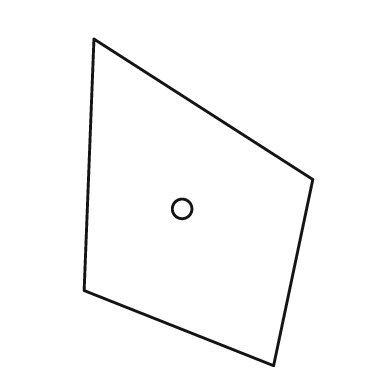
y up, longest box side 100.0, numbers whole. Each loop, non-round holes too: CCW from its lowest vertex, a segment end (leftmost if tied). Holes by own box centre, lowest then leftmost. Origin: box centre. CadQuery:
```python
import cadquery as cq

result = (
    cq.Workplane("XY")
    .moveTo(23.0, -50.0)
    .lineTo(35.0, 7.0)
    .lineTo(-32.0, 50.0)
    .lineTo(-35.0, -27.0)
    .close()
    .moveTo(-5.0, -2.0)
    .circle(3.0)
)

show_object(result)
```